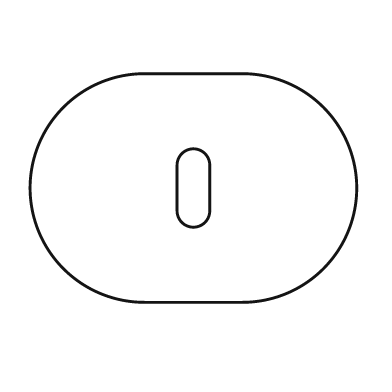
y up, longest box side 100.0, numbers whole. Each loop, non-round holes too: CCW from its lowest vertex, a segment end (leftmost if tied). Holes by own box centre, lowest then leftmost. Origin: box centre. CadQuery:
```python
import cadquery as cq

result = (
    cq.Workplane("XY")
    .moveTo(-15.0, -35.0)
    .lineTo(15.0, -35.0)
    .threePointArc((50.0, 0.0), (15.0, 35.0))
    .lineTo(-15.0, 35.0)
    .threePointArc((-50.0, 0.0), (-15.0, -35.0))
    .close()
    .moveTo(-5.0, -7.0)
    .threePointArc((0.0, -12.0), (5.0, -7.0))
    .lineTo(5.0, 7.0)
    .threePointArc((0.0, 12.0), (-5.0, 7.0))
    .close()
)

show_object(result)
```